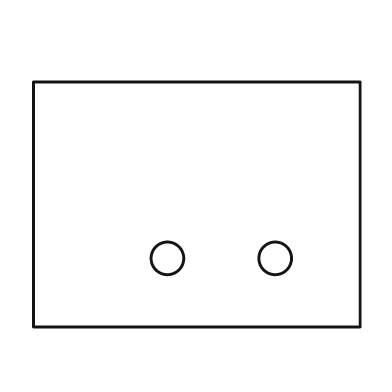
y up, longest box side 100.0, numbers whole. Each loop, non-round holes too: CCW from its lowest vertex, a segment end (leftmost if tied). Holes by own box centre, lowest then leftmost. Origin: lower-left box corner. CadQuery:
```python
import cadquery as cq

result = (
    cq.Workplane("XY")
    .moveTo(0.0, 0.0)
    .lineTo(100.0, 0.0)
    .lineTo(100.0, 75.0)
    .lineTo(0.0, 75.0)
    .close()
    .moveTo(41.0, 21.0)
    .circle(5.0)
    .moveTo(74.0, 21.0)
    .circle(5.0)
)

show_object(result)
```